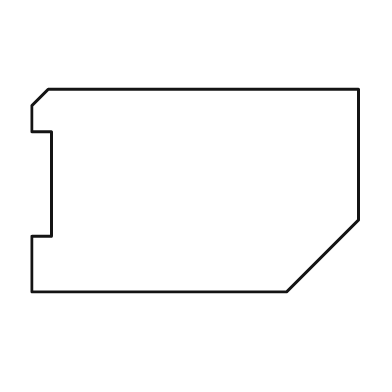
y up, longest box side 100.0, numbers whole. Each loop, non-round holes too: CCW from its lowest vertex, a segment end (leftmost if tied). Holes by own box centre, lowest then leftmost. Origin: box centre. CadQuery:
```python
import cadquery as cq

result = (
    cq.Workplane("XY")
    .moveTo(-50.0, -31.0)
    .lineTo(28.0, -31.0)
    .lineTo(50.0, -9.0)
    .lineTo(50.0, 31.0)
    .lineTo(-45.0, 31.0)
    .lineTo(-50.0, 26.0)
    .lineTo(-50.0, 18.0)
    .lineTo(-44.0, 18.0)
    .lineTo(-44.0, -14.0)
    .lineTo(-50.0, -14.0)
    .close()
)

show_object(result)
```